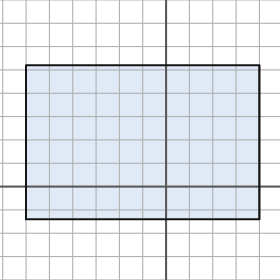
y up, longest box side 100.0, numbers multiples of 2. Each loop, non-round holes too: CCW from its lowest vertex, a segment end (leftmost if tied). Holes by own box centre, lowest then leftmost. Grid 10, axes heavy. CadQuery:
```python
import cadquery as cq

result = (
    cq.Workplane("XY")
    .moveTo(-60.0, -14.0)
    .lineTo(40.0, -14.0)
    .lineTo(40.0, 52.0)
    .lineTo(-60.0, 52.0)
    .close()
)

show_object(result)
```